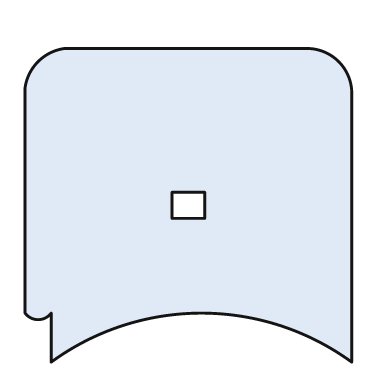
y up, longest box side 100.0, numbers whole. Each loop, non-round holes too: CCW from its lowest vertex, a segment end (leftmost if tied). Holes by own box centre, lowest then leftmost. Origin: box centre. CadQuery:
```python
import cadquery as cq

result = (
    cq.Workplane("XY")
    .moveTo(-42.0, -48.0)
    .threePointArc((4.0, -33.0), (50.0, -48.0))
    .lineTo(50.0, 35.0)
    .threePointArc((46.0, 44.0), (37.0, 48.0))
    .lineTo(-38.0, 48.0)
    .threePointArc((-46.0, 44.0), (-50.0, 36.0))
    .lineTo(-50.0, -33.0)
    .threePointArc((-46.0, -35.0), (-42.0, -33.0))
    .close()
    .moveTo(-5.0, -4.0)
    .lineTo(5.0, -4.0)
    .lineTo(5.0, 4.0)
    .lineTo(-5.0, 4.0)
    .close()
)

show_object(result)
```